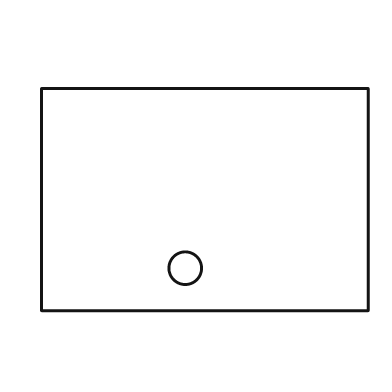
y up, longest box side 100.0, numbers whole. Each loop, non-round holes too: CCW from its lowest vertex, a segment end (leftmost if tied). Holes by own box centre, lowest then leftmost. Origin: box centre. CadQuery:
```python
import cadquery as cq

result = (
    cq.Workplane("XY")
    .moveTo(-50.0, -34.0)
    .lineTo(50.0, -34.0)
    .lineTo(50.0, 34.0)
    .lineTo(-50.0, 34.0)
    .close()
    .moveTo(-6.0, -21.0)
    .circle(5.0)
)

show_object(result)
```